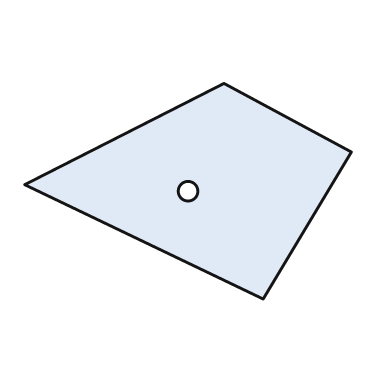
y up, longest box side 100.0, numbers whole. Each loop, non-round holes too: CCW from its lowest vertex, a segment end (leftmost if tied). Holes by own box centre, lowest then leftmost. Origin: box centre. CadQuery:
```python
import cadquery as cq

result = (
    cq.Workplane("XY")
    .moveTo(23.0, -33.0)
    .lineTo(50.0, 12.0)
    .lineTo(11.0, 33.0)
    .lineTo(-50.0, 2.0)
    .close()
    .moveTo(0.0, 0.0)
    .circle(3.0)
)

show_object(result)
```